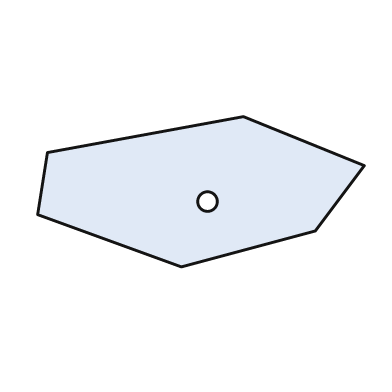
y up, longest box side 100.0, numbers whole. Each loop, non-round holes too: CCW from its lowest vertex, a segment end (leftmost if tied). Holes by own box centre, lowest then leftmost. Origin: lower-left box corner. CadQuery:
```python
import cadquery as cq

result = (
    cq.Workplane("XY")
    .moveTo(44.0, 0.0)
    .lineTo(85.0, 11.0)
    .lineTo(100.0, 31.0)
    .lineTo(63.0, 46.0)
    .lineTo(3.0, 35.0)
    .lineTo(0.0, 16.0)
    .close()
    .moveTo(52.0, 20.0)
    .circle(3.0)
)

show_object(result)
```